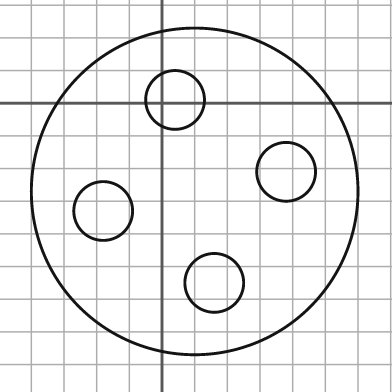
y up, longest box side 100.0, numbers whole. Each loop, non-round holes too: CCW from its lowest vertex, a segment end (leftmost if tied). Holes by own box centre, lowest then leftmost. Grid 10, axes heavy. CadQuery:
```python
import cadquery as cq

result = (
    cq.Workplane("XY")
    .moveTo(10.0, -27.0)
    .circle(50.0)
    .moveTo(16.0, -55.0)
    .circle(9.0)
    .moveTo(-18.0, -33.0)
    .circle(9.0)
    .moveTo(38.0, -21.0)
    .circle(9.0)
    .moveTo(4.0, 1.0)
    .circle(9.0)
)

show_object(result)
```